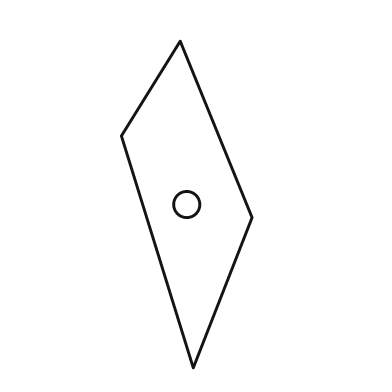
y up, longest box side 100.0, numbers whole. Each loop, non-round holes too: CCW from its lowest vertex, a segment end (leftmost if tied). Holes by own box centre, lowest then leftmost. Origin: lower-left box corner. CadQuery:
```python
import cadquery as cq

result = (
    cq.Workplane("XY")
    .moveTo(22.0, 0.0)
    .lineTo(40.0, 46.0)
    .lineTo(18.0, 100.0)
    .lineTo(0.0, 71.0)
    .close()
    .moveTo(20.0, 50.0)
    .circle(4.0)
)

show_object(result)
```